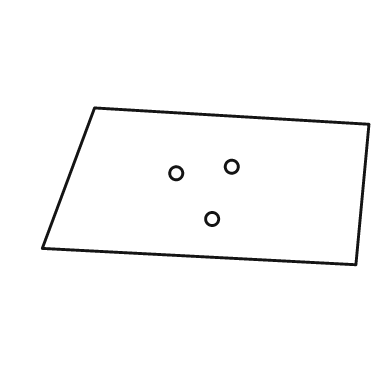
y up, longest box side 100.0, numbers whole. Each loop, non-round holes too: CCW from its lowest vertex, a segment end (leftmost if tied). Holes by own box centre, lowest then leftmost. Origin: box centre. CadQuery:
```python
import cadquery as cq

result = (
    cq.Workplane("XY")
    .moveTo(46.0, -24.0)
    .lineTo(50.0, 19.0)
    .lineTo(-34.0, 24.0)
    .lineTo(-50.0, -19.0)
    .close()
    .moveTo(2.0, -10.0)
    .circle(2.0)
    .moveTo(-9.0, 4.0)
    .circle(2.0)
    .moveTo(8.0, 6.0)
    .circle(2.0)
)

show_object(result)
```